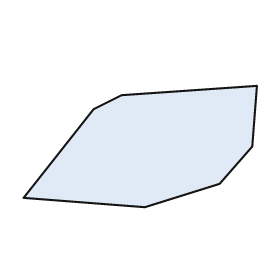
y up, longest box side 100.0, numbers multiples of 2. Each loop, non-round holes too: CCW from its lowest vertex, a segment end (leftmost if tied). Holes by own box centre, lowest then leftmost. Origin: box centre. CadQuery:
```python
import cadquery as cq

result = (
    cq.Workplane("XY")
    .moveTo(2.0, -26.0)
    .lineTo(34.0, -16.0)
    .lineTo(48.0, 0.0)
    .lineTo(50.0, 26.0)
    .lineTo(-8.0, 22.0)
    .lineTo(-20.0, 16.0)
    .lineTo(-50.0, -22.0)
    .close()
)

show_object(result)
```